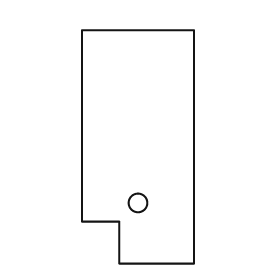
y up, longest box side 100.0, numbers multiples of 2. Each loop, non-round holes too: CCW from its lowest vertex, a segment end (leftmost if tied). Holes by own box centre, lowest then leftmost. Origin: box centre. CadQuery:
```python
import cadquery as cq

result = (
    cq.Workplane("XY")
    .moveTo(-8.0, -50.0)
    .lineTo(24.0, -50.0)
    .lineTo(24.0, 50.0)
    .lineTo(-24.0, 50.0)
    .lineTo(-24.0, -32.0)
    .lineTo(-8.0, -32.0)
    .close()
    .moveTo(0.0, -24.0)
    .circle(4.0)
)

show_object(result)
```